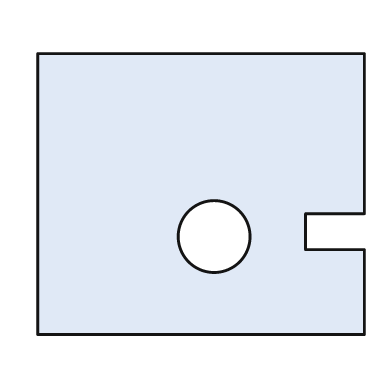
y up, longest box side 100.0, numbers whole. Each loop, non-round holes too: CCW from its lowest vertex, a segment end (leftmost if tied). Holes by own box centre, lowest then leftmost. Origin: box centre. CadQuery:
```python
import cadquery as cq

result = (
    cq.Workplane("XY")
    .moveTo(-50.0, -43.0)
    .lineTo(50.0, -43.0)
    .lineTo(50.0, -17.0)
    .lineTo(32.0, -17.0)
    .lineTo(32.0, -6.0)
    .lineTo(50.0, -6.0)
    .lineTo(50.0, 43.0)
    .lineTo(-50.0, 43.0)
    .close()
    .moveTo(4.0, -13.0)
    .circle(11.0)
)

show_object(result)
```